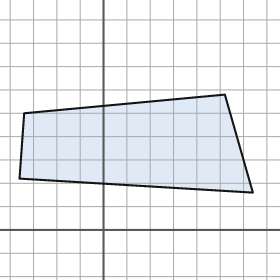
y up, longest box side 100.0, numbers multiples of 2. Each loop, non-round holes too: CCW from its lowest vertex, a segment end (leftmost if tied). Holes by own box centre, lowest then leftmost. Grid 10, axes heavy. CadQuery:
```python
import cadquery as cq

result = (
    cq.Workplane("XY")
    .moveTo(64.0, 16.0)
    .lineTo(52.0, 58.0)
    .lineTo(-34.0, 50.0)
    .lineTo(-36.0, 22.0)
    .close()
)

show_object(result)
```